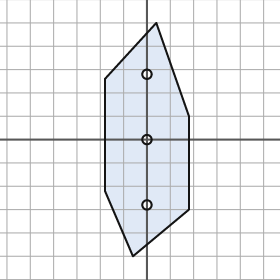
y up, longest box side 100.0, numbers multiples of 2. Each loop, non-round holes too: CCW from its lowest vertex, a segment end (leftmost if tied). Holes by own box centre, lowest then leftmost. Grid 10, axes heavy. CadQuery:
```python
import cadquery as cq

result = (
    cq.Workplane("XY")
    .moveTo(-6.0, -50.0)
    .lineTo(18.0, -30.0)
    .lineTo(18.0, 10.0)
    .lineTo(4.0, 50.0)
    .lineTo(-18.0, 26.0)
    .lineTo(-18.0, -22.0)
    .close()
    .moveTo(0.0, -28.0)
    .circle(2.0)
    .moveTo(0.0, 0.0)
    .circle(2.0)
    .moveTo(0.0, 28.0)
    .circle(2.0)
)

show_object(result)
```